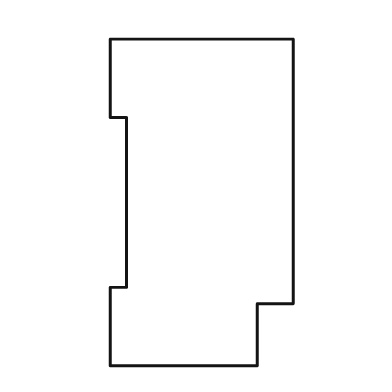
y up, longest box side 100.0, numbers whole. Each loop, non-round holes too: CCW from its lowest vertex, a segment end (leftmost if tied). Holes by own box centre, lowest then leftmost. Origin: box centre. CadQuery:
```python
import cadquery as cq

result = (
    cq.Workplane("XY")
    .moveTo(-28.0, -50.0)
    .lineTo(17.0, -50.0)
    .lineTo(17.0, -31.0)
    .lineTo(28.0, -31.0)
    .lineTo(28.0, 50.0)
    .lineTo(-28.0, 50.0)
    .lineTo(-28.0, 26.0)
    .lineTo(-23.0, 26.0)
    .lineTo(-23.0, -26.0)
    .lineTo(-28.0, -26.0)
    .close()
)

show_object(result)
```